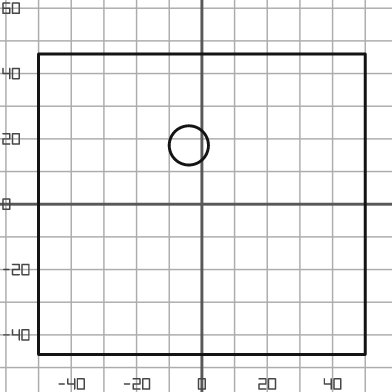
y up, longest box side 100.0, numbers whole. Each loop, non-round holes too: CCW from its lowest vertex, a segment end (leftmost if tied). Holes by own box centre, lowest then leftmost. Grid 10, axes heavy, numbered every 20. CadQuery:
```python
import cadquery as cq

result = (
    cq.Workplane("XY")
    .moveTo(-50.0, -46.0)
    .lineTo(50.0, -46.0)
    .lineTo(50.0, 46.0)
    .lineTo(-50.0, 46.0)
    .close()
    .moveTo(-4.0, 18.0)
    .circle(6.0)
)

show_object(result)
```